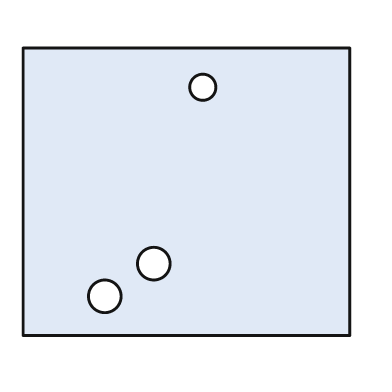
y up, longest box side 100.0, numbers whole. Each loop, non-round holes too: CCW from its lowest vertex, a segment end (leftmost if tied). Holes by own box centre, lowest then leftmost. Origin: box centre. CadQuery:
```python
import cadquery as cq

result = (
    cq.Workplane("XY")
    .moveTo(-50.0, -44.0)
    .lineTo(50.0, -44.0)
    .lineTo(50.0, 44.0)
    .lineTo(-50.0, 44.0)
    .close()
    .moveTo(-25.0, -32.0)
    .circle(5.0)
    .moveTo(-10.0, -22.0)
    .circle(5.0)
    .moveTo(5.0, 32.0)
    .circle(4.0)
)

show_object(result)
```